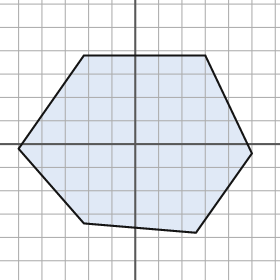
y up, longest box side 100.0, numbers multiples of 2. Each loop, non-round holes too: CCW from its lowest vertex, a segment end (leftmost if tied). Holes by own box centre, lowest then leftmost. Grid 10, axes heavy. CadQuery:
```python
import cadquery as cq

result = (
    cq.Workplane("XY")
    .moveTo(26.0, -38.0)
    .lineTo(50.0, -4.0)
    .lineTo(30.0, 38.0)
    .lineTo(-22.0, 38.0)
    .lineTo(-50.0, -2.0)
    .lineTo(-22.0, -34.0)
    .close()
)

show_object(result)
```